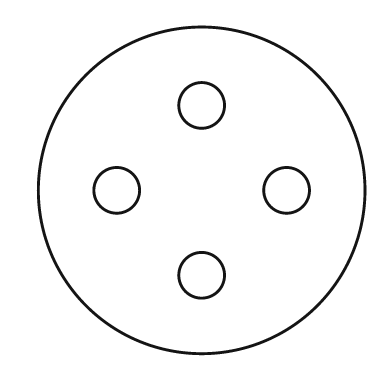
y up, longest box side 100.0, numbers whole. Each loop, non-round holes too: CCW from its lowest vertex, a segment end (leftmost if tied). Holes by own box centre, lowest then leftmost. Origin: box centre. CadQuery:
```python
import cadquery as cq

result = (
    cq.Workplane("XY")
    .moveTo(0.0, 0.0)
    .circle(50.0)
    .moveTo(0.0, -26.0)
    .circle(7.0)
    .moveTo(-26.0, 0.0)
    .circle(7.0)
    .moveTo(26.0, 0.0)
    .circle(7.0)
    .moveTo(0.0, 26.0)
    .circle(7.0)
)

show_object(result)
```